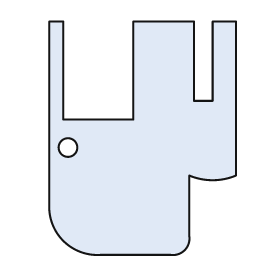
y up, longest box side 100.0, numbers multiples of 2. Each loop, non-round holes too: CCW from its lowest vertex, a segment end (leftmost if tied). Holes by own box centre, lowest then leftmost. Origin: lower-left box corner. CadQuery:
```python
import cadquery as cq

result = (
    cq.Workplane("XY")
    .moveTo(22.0, 0.0)
    .lineTo(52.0, 0.0)
    .threePointArc((58.0, 2.0), (60.0, 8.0))
    .lineTo(60.0, 34.0)
    .threePointArc((70.0, 32.0), (80.0, 34.0))
    .lineTo(80.0, 100.0)
    .lineTo(70.0, 100.0)
    .lineTo(70.0, 66.0)
    .lineTo(62.0, 66.0)
    .lineTo(62.0, 100.0)
    .lineTo(36.0, 100.0)
    .lineTo(36.0, 58.0)
    .lineTo(6.0, 58.0)
    .lineTo(6.0, 100.0)
    .lineTo(0.0, 100.0)
    .lineTo(0.0, 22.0)
    .threePointArc((6.0, 6.0), (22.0, 0.0))
    .close()
    .moveTo(8.0, 46.0)
    .circle(4.0)
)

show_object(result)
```